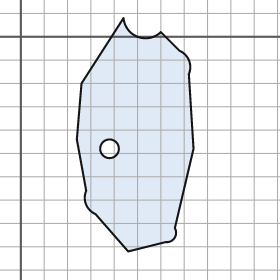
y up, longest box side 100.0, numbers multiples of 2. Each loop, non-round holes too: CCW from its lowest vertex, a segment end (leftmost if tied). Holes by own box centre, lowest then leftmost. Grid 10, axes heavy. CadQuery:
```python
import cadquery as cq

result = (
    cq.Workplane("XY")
    .moveTo(46.0, -92.0)
    .lineTo(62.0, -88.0)
    .threePointArc((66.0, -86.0), (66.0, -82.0))
    .lineTo(74.0, -48.0)
    .lineTo(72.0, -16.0)
    .threePointArc((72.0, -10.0), (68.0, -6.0))
    .lineTo(60.0, 2.0)
    .threePointArc((50.0, 0.0), (44.0, 8.0))
    .lineTo(26.0, -20.0)
    .lineTo(24.0, -44.0)
    .lineTo(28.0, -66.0)
    .threePointArc((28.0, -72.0), (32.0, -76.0))
    .close()
    .moveTo(38.0, -48.0)
    .circle(4.0)
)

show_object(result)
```